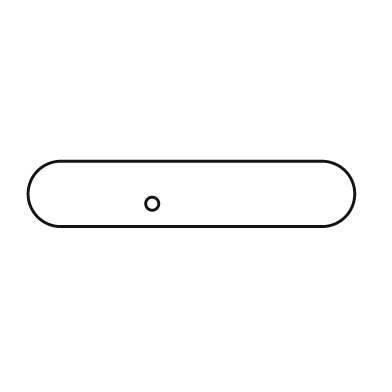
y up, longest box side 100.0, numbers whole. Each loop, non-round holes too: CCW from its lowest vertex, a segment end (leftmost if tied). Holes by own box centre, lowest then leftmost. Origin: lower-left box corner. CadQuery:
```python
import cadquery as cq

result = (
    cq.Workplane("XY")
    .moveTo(10.0, 0.0)
    .lineTo(90.0, 0.0)
    .threePointArc((100.0, 10.0), (90.0, 20.0))
    .lineTo(10.0, 20.0)
    .threePointArc((0.0, 10.0), (10.0, 0.0))
    .close()
    .moveTo(38.0, 7.0)
    .circle(2.0)
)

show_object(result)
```